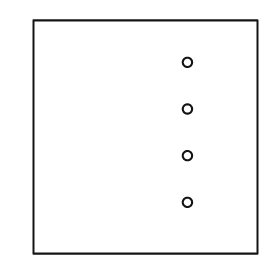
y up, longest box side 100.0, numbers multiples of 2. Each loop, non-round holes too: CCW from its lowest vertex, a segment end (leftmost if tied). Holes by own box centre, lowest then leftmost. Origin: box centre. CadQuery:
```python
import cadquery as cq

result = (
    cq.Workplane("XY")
    .moveTo(-48.0, -50.0)
    .lineTo(48.0, -50.0)
    .lineTo(48.0, 50.0)
    .lineTo(-48.0, 50.0)
    .close()
    .moveTo(18.0, -28.0)
    .circle(2.0)
    .moveTo(18.0, -8.0)
    .circle(2.0)
    .moveTo(18.0, 12.0)
    .circle(2.0)
    .moveTo(18.0, 32.0)
    .circle(2.0)
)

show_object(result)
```